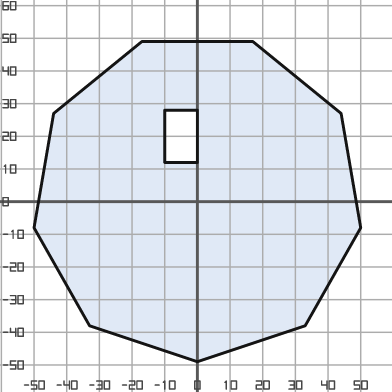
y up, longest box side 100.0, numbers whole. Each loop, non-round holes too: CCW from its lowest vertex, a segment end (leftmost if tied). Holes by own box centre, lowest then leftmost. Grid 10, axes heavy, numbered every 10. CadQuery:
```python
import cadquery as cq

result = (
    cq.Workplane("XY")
    .moveTo(0.0, -49.0)
    .lineTo(33.0, -38.0)
    .lineTo(50.0, -8.0)
    .lineTo(44.0, 27.0)
    .lineTo(17.0, 49.0)
    .lineTo(-17.0, 49.0)
    .lineTo(-44.0, 27.0)
    .lineTo(-50.0, -8.0)
    .lineTo(-33.0, -38.0)
    .close()
    .moveTo(-10.0, 12.0)
    .lineTo(0.0, 12.0)
    .lineTo(0.0, 28.0)
    .lineTo(-10.0, 28.0)
    .close()
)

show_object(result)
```